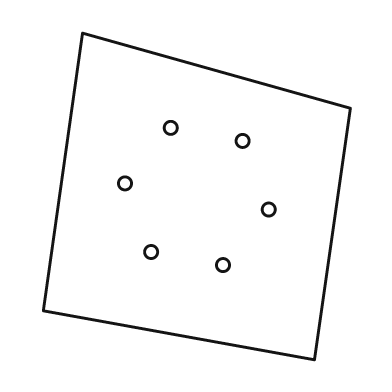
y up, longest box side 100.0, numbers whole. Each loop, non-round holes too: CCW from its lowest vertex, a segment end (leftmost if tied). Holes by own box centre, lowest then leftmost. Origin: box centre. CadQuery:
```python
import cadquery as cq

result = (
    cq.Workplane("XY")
    .moveTo(36.0, -50.0)
    .lineTo(47.0, 27.0)
    .lineTo(-35.0, 50.0)
    .lineTo(-47.0, -35.0)
    .close()
    .moveTo(8.0, -21.0)
    .circle(2.0)
    .moveTo(-14.0, -17.0)
    .circle(2.0)
    .moveTo(22.0, -4.0)
    .circle(2.0)
    .moveTo(-22.0, 4.0)
    .circle(2.0)
    .moveTo(14.0, 17.0)
    .circle(2.0)
    .moveTo(-8.0, 21.0)
    .circle(2.0)
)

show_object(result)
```